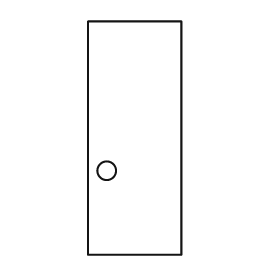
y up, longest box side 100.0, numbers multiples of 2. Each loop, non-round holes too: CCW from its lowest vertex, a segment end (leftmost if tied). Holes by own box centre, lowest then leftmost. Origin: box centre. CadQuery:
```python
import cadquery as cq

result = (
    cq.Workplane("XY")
    .moveTo(-20.0, -50.0)
    .lineTo(20.0, -50.0)
    .lineTo(20.0, 50.0)
    .lineTo(-20.0, 50.0)
    .close()
    .moveTo(-12.0, -14.0)
    .circle(4.0)
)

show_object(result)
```